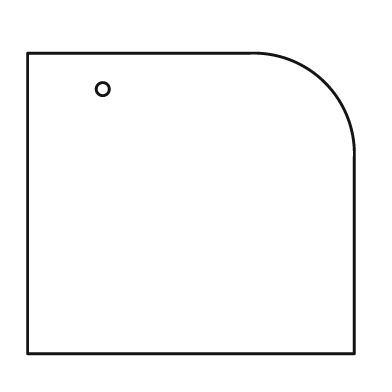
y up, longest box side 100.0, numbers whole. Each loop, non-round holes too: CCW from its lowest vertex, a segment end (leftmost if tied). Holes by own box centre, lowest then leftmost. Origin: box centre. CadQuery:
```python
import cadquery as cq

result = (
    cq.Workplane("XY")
    .moveTo(-50.0, -46.0)
    .lineTo(50.0, -46.0)
    .lineTo(50.0, 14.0)
    .threePointArc((41.0, 37.0), (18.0, 46.0))
    .lineTo(-50.0, 46.0)
    .close()
    .moveTo(-27.0, 35.0)
    .circle(2.0)
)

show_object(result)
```